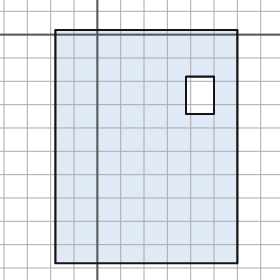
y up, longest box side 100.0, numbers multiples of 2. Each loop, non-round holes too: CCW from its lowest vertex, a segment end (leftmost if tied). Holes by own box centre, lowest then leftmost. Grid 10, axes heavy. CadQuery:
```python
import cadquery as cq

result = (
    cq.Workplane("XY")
    .moveTo(-18.0, -98.0)
    .lineTo(60.0, -98.0)
    .lineTo(60.0, 2.0)
    .lineTo(-18.0, 2.0)
    .close()
    .moveTo(38.0, -34.0)
    .lineTo(50.0, -34.0)
    .lineTo(50.0, -18.0)
    .lineTo(38.0, -18.0)
    .close()
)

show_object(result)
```